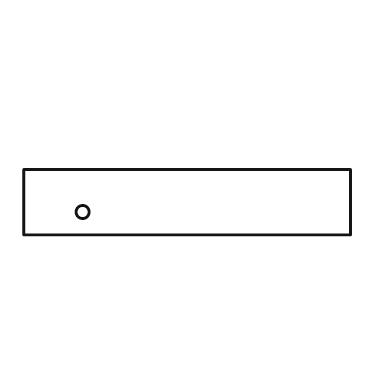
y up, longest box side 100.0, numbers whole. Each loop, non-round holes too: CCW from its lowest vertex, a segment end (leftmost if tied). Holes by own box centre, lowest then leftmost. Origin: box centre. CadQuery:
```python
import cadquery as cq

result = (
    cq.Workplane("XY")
    .moveTo(-50.0, -10.0)
    .lineTo(50.0, -10.0)
    .lineTo(50.0, 10.0)
    .lineTo(-50.0, 10.0)
    .close()
    .moveTo(-32.0, -3.0)
    .circle(2.0)
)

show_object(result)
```